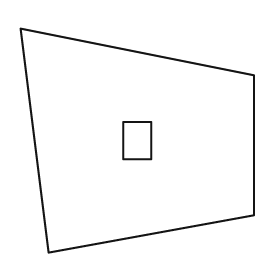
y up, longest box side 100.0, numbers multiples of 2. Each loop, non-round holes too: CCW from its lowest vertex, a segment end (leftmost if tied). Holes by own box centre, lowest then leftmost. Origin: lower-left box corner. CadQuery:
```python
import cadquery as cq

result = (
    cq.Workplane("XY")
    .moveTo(12.0, 0.0)
    .lineTo(100.0, 16.0)
    .lineTo(100.0, 76.0)
    .lineTo(0.0, 96.0)
    .close()
    .moveTo(44.0, 40.0)
    .lineTo(56.0, 40.0)
    .lineTo(56.0, 56.0)
    .lineTo(44.0, 56.0)
    .close()
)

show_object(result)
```